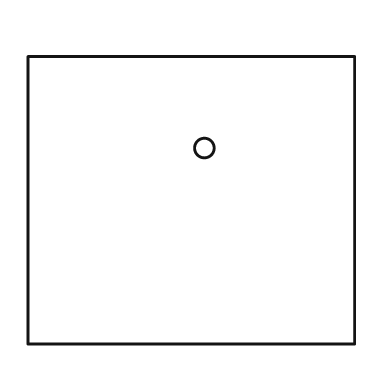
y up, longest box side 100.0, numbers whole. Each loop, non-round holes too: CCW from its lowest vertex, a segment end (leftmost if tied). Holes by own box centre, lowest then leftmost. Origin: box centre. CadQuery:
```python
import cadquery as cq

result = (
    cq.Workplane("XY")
    .moveTo(-50.0, -44.0)
    .lineTo(50.0, -44.0)
    .lineTo(50.0, 44.0)
    .lineTo(-50.0, 44.0)
    .close()
    .moveTo(4.0, 16.0)
    .circle(3.0)
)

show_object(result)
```